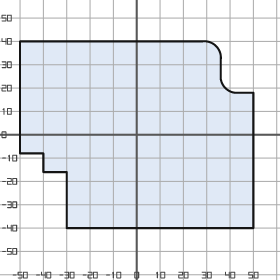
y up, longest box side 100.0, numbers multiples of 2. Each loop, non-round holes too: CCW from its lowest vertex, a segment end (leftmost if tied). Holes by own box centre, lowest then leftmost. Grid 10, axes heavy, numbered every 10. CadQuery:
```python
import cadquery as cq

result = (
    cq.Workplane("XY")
    .moveTo(-30.0, -40.0)
    .lineTo(50.0, -40.0)
    .lineTo(50.0, 18.0)
    .lineTo(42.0, 18.0)
    .threePointArc((38.0, 20.0), (36.0, 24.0))
    .lineTo(36.0, 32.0)
    .threePointArc((34.0, 38.0), (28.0, 40.0))
    .lineTo(-50.0, 40.0)
    .lineTo(-50.0, -8.0)
    .lineTo(-40.0, -8.0)
    .lineTo(-40.0, -16.0)
    .lineTo(-30.0, -16.0)
    .close()
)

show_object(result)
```